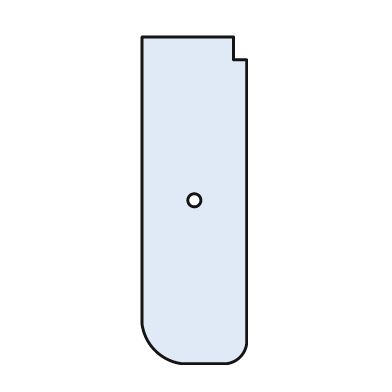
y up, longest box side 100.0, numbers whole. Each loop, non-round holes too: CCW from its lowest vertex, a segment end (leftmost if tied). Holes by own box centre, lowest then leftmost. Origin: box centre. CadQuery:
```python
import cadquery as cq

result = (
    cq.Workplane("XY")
    .moveTo(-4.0, -50.0)
    .lineTo(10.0, -50.0)
    .threePointArc((14.0, -48.0), (16.0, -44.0))
    .lineTo(16.0, 43.0)
    .lineTo(12.0, 43.0)
    .lineTo(12.0, 50.0)
    .lineTo(-16.0, 50.0)
    .lineTo(-16.0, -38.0)
    .threePointArc((-12.0, -46.0), (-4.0, -50.0))
    .close()
    .moveTo(0.0, 0.0)
    .circle(2.0)
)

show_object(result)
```